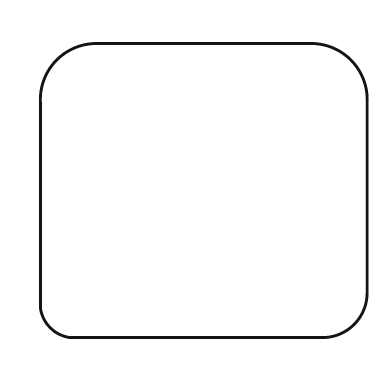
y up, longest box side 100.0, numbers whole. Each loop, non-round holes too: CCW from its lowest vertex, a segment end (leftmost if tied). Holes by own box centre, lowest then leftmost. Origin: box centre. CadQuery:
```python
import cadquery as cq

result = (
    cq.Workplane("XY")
    .moveTo(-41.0, -45.0)
    .lineTo(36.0, -45.0)
    .threePointArc((46.0, -41.0), (50.0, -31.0))
    .lineTo(50.0, 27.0)
    .threePointArc((45.0, 40.0), (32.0, 45.0))
    .lineTo(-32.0, 45.0)
    .threePointArc((-45.0, 40.0), (-50.0, 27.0))
    .lineTo(-50.0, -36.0)
    .threePointArc((-47.0, -42.0), (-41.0, -45.0))
    .close()
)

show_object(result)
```